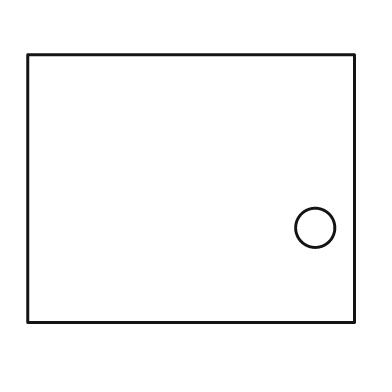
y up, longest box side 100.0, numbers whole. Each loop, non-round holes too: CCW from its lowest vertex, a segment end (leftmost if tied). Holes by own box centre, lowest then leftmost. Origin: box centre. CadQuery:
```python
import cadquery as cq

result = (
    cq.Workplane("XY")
    .moveTo(-50.0, -41.0)
    .lineTo(50.0, -41.0)
    .lineTo(50.0, 41.0)
    .lineTo(-50.0, 41.0)
    .close()
    .moveTo(38.0, -12.0)
    .circle(6.0)
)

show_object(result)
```